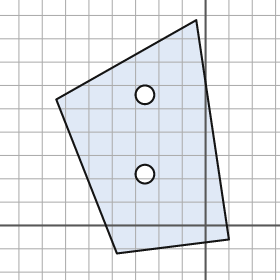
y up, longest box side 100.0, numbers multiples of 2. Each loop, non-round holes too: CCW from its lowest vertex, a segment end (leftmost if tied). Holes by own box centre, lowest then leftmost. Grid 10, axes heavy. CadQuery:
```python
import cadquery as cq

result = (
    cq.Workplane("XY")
    .moveTo(-38.0, -12.0)
    .lineTo(10.0, -6.0)
    .lineTo(-4.0, 88.0)
    .lineTo(-64.0, 54.0)
    .close()
    .moveTo(-26.0, 22.0)
    .circle(4.0)
    .moveTo(-26.0, 56.0)
    .circle(4.0)
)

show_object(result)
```